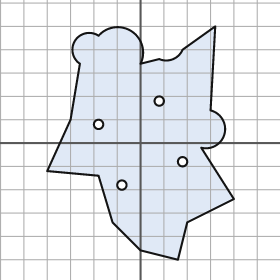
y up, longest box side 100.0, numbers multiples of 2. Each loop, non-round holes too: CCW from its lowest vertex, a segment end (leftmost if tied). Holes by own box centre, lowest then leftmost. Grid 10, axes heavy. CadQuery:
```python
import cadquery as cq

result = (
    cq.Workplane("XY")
    .moveTo(16.0, -50.0)
    .lineTo(20.0, -34.0)
    .lineTo(40.0, -24.0)
    .lineTo(26.0, -2.0)
    .threePointArc((36.0, 4.0), (30.0, 14.0))
    .lineTo(32.0, 50.0)
    .lineTo(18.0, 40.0)
    .threePointArc((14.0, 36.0), (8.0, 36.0))
    .lineTo(0.0, 34.0)
    .threePointArc((-4.0, 48.0), (-18.0, 46.0))
    .threePointArc((-28.0, 44.0), (-26.0, 34.0))
    .lineTo(-30.0, 10.0)
    .lineTo(-40.0, -12.0)
    .lineTo(-18.0, -14.0)
    .lineTo(-12.0, -34.0)
    .lineTo(0.0, -46.0)
    .close()
    .moveTo(-8.0, -18.0)
    .circle(2.0)
    .moveTo(18.0, -8.0)
    .circle(2.0)
    .moveTo(-18.0, 8.0)
    .circle(2.0)
    .moveTo(8.0, 18.0)
    .circle(2.0)
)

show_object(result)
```